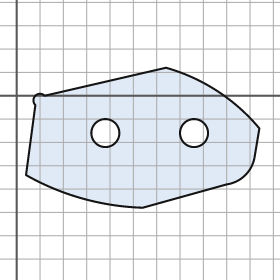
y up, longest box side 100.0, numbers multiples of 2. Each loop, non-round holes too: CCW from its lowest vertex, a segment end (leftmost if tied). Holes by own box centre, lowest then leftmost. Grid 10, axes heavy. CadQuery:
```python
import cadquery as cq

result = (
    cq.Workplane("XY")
    .moveTo(54.0, -48.0)
    .lineTo(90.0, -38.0)
    .threePointArc((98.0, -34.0), (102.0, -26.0))
    .lineTo(104.0, -14.0)
    .threePointArc((86.0, 2.0), (64.0, 12.0))
    .lineTo(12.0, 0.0)
    .threePointArc((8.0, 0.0), (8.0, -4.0))
    .lineTo(4.0, -34.0)
    .threePointArc((28.0, -44.0), (54.0, -48.0))
    .close()
    .moveTo(38.0, -16.0)
    .circle(6.0)
    .moveTo(76.0, -16.0)
    .circle(6.0)
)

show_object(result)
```